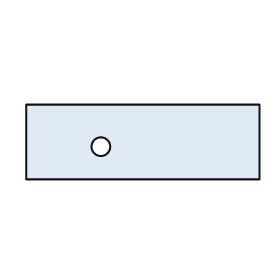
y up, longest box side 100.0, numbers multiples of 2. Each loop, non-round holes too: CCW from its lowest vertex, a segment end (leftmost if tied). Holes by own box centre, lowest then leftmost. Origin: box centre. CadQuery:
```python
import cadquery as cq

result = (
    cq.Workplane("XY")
    .moveTo(-50.0, -16.0)
    .lineTo(50.0, -16.0)
    .lineTo(50.0, 16.0)
    .lineTo(-50.0, 16.0)
    .close()
    .moveTo(-18.0, -2.0)
    .circle(4.0)
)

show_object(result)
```